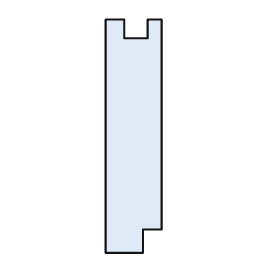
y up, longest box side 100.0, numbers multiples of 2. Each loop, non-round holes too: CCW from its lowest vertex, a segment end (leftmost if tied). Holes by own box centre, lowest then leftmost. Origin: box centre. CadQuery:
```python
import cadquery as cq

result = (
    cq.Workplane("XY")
    .moveTo(-12.0, -50.0)
    .lineTo(4.0, -50.0)
    .lineTo(4.0, -40.0)
    .lineTo(12.0, -40.0)
    .lineTo(12.0, 50.0)
    .lineTo(6.0, 50.0)
    .lineTo(6.0, 42.0)
    .lineTo(-4.0, 42.0)
    .lineTo(-4.0, 50.0)
    .lineTo(-12.0, 50.0)
    .close()
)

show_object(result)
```